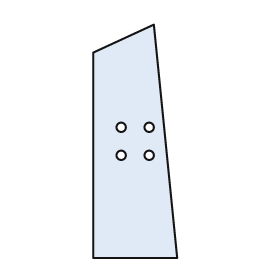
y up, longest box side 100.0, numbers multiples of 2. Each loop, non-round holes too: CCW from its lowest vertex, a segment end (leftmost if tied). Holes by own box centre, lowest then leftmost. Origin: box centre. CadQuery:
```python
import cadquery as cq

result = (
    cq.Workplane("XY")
    .moveTo(-18.0, -50.0)
    .lineTo(18.0, -50.0)
    .lineTo(8.0, 50.0)
    .lineTo(-18.0, 38.0)
    .close()
    .moveTo(-6.0, -6.0)
    .circle(2.0)
    .moveTo(6.0, -6.0)
    .circle(2.0)
    .moveTo(-6.0, 6.0)
    .circle(2.0)
    .moveTo(6.0, 6.0)
    .circle(2.0)
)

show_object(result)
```